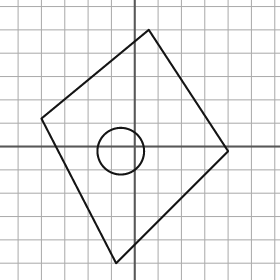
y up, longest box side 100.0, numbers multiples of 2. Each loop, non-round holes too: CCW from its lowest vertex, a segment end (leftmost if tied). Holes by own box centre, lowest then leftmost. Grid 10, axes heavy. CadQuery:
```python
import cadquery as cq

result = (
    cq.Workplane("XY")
    .moveTo(-8.0, -50.0)
    .lineTo(40.0, -2.0)
    .lineTo(6.0, 50.0)
    .lineTo(-40.0, 12.0)
    .close()
    .moveTo(-6.0, -2.0)
    .circle(10.0)
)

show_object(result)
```